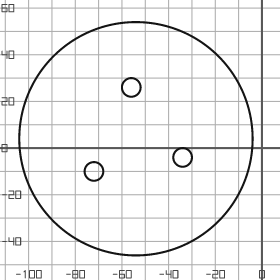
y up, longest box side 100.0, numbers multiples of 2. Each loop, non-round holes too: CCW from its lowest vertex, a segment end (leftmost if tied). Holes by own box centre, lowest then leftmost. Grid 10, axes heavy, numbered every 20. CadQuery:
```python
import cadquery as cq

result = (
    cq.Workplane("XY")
    .moveTo(-54.0, 4.0)
    .circle(50.0)
    .moveTo(-72.0, -10.0)
    .circle(4.0)
    .moveTo(-34.0, -4.0)
    .circle(4.0)
    .moveTo(-56.0, 26.0)
    .circle(4.0)
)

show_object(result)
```